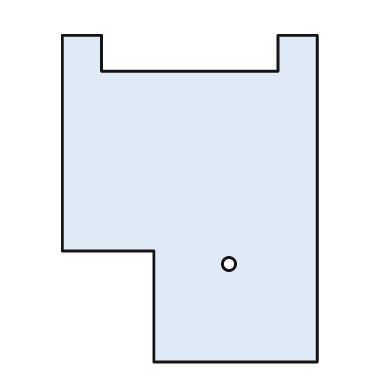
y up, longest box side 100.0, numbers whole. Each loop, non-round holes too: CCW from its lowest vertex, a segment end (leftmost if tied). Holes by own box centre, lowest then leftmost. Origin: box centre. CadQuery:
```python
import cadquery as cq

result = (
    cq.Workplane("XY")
    .moveTo(-11.0, -50.0)
    .lineTo(39.0, -50.0)
    .lineTo(39.0, 50.0)
    .lineTo(27.0, 50.0)
    .lineTo(27.0, 39.0)
    .lineTo(-27.0, 39.0)
    .lineTo(-27.0, 50.0)
    .lineTo(-39.0, 50.0)
    .lineTo(-39.0, -16.0)
    .lineTo(-11.0, -16.0)
    .close()
    .moveTo(12.0, -20.0)
    .circle(2.0)
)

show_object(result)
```